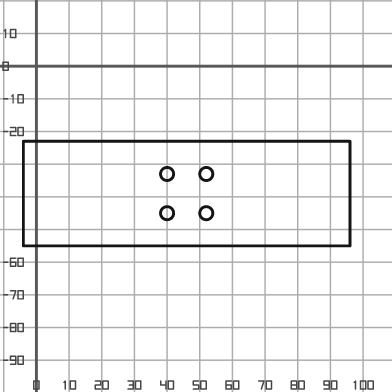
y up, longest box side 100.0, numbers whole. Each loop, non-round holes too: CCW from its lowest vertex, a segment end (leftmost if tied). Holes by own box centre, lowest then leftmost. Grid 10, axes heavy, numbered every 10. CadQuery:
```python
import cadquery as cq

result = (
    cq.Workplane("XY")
    .moveTo(-4.0, -55.0)
    .lineTo(96.0, -55.0)
    .lineTo(96.0, -23.0)
    .lineTo(-4.0, -23.0)
    .close()
    .moveTo(40.0, -45.0)
    .circle(2.0)
    .moveTo(52.0, -45.0)
    .circle(2.0)
    .moveTo(40.0, -33.0)
    .circle(2.0)
    .moveTo(52.0, -33.0)
    .circle(2.0)
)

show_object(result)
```